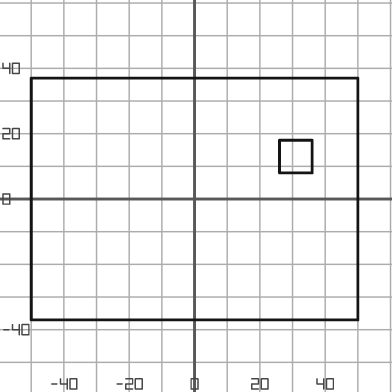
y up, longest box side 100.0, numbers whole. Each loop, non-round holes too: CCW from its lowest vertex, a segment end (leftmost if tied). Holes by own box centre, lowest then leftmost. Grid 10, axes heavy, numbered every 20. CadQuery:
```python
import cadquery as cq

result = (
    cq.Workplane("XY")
    .moveTo(-50.0, -37.0)
    .lineTo(50.0, -37.0)
    .lineTo(50.0, 37.0)
    .lineTo(-50.0, 37.0)
    .close()
    .moveTo(26.0, 8.0)
    .lineTo(36.0, 8.0)
    .lineTo(36.0, 18.0)
    .lineTo(26.0, 18.0)
    .close()
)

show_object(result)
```